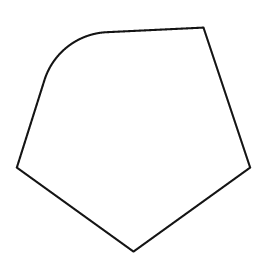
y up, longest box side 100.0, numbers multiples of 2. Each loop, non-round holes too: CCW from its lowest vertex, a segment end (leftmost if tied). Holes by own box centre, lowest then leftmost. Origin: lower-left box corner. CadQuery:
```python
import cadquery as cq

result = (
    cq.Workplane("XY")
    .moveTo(50.0, 0.0)
    .lineTo(100.0, 36.0)
    .lineTo(80.0, 96.0)
    .lineTo(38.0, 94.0)
    .threePointArc((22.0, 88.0), (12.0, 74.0))
    .lineTo(0.0, 36.0)
    .close()
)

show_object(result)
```